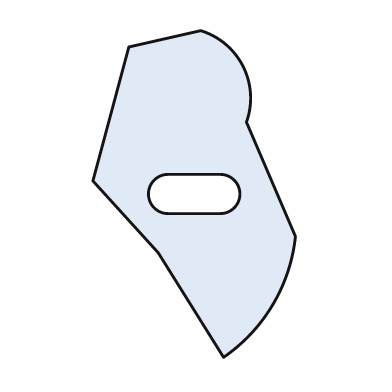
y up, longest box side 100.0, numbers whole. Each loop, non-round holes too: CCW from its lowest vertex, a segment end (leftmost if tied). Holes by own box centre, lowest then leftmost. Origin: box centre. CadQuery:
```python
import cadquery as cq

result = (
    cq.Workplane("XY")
    .moveTo(9.0, -50.0)
    .threePointArc((24.0, -34.0), (31.0, -13.0))
    .lineTo(16.0, 22.0)
    .threePointArc((15.0, 39.0), (2.0, 50.0))
    .lineTo(-20.0, 45.0)
    .lineTo(-31.0, 4.0)
    .lineTo(-11.0, -18.0)
    .close()
    .moveTo(-8.0, -6.0)
    .lineTo(8.0, -6.0)
    .threePointArc((14.0, 0.0), (8.0, 6.0))
    .lineTo(-8.0, 6.0)
    .threePointArc((-14.0, 0.0), (-8.0, -6.0))
    .close()
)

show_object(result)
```